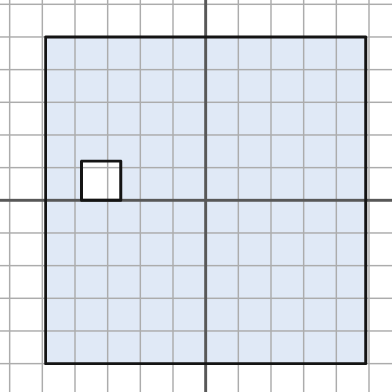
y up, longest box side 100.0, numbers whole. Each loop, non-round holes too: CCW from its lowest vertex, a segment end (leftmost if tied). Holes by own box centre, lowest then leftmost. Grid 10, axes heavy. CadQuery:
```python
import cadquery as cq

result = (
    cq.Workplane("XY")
    .moveTo(-49.0, -50.0)
    .lineTo(49.0, -50.0)
    .lineTo(49.0, 50.0)
    .lineTo(-49.0, 50.0)
    .close()
    .moveTo(-38.0, 0.0)
    .lineTo(-26.0, 0.0)
    .lineTo(-26.0, 12.0)
    .lineTo(-38.0, 12.0)
    .close()
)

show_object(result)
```